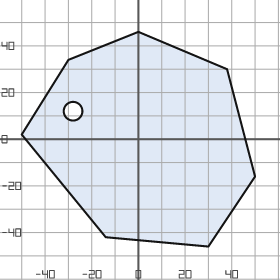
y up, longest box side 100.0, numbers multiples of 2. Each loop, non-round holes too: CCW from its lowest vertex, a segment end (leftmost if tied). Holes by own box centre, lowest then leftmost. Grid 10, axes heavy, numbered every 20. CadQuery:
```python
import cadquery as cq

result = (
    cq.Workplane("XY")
    .moveTo(30.0, -46.0)
    .lineTo(50.0, -16.0)
    .lineTo(38.0, 30.0)
    .lineTo(0.0, 46.0)
    .lineTo(-30.0, 34.0)
    .lineTo(-50.0, 2.0)
    .lineTo(-14.0, -42.0)
    .close()
    .moveTo(-28.0, 12.0)
    .circle(4.0)
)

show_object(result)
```